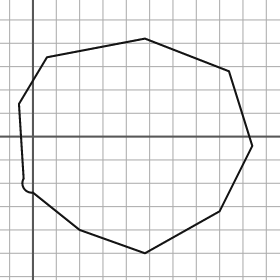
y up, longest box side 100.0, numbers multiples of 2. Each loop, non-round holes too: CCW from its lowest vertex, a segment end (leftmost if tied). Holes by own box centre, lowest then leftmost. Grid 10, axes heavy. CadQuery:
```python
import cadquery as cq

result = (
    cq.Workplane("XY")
    .moveTo(48.0, -50.0)
    .lineTo(80.0, -32.0)
    .lineTo(94.0, -4.0)
    .lineTo(84.0, 28.0)
    .lineTo(48.0, 42.0)
    .lineTo(6.0, 34.0)
    .lineTo(-6.0, 14.0)
    .lineTo(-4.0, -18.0)
    .threePointArc((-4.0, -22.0), (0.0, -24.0))
    .lineTo(20.0, -40.0)
    .close()
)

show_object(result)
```